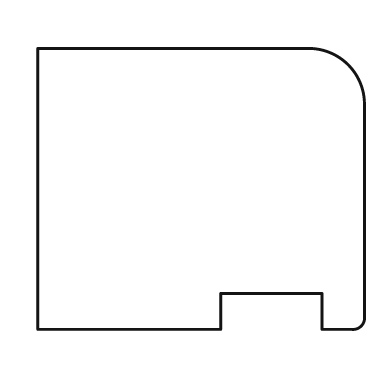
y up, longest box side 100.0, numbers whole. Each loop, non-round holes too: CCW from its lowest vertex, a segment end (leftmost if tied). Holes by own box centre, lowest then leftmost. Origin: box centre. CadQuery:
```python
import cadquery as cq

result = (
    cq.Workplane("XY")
    .moveTo(-50.0, -43.0)
    .lineTo(6.0, -43.0)
    .lineTo(6.0, -32.0)
    .lineTo(37.0, -32.0)
    .lineTo(37.0, -43.0)
    .lineTo(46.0, -43.0)
    .threePointArc((49.0, -42.0), (50.0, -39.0))
    .lineTo(50.0, 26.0)
    .threePointArc((45.0, 38.0), (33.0, 43.0))
    .lineTo(-50.0, 43.0)
    .close()
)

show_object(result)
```